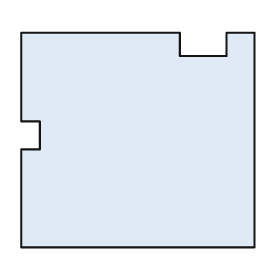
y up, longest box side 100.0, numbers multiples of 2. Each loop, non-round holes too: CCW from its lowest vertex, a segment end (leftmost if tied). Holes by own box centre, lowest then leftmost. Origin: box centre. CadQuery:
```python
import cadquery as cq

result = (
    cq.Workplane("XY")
    .moveTo(-50.0, -46.0)
    .lineTo(50.0, -46.0)
    .lineTo(50.0, 46.0)
    .lineTo(38.0, 46.0)
    .lineTo(38.0, 36.0)
    .lineTo(18.0, 36.0)
    .lineTo(18.0, 46.0)
    .lineTo(-50.0, 46.0)
    .lineTo(-50.0, 8.0)
    .lineTo(-42.0, 8.0)
    .lineTo(-42.0, -4.0)
    .lineTo(-50.0, -4.0)
    .close()
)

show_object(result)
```